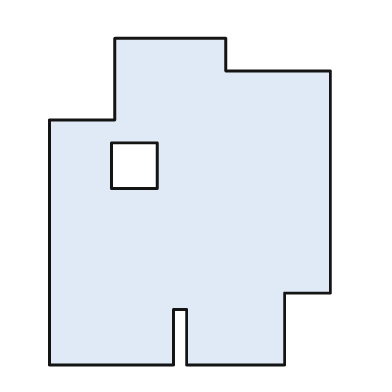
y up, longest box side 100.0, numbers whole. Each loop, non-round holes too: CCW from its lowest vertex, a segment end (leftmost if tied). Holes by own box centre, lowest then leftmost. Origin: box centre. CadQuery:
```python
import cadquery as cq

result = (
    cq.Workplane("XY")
    .moveTo(-43.0, -50.0)
    .lineTo(-5.0, -50.0)
    .lineTo(-5.0, -33.0)
    .lineTo(-1.0, -33.0)
    .lineTo(-1.0, -50.0)
    .lineTo(29.0, -50.0)
    .lineTo(29.0, -28.0)
    .lineTo(43.0, -28.0)
    .lineTo(43.0, 40.0)
    .lineTo(11.0, 40.0)
    .lineTo(11.0, 50.0)
    .lineTo(-23.0, 50.0)
    .lineTo(-23.0, 25.0)
    .lineTo(-43.0, 25.0)
    .close()
    .moveTo(-24.0, 4.0)
    .lineTo(-10.0, 4.0)
    .lineTo(-10.0, 18.0)
    .lineTo(-24.0, 18.0)
    .close()
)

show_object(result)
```